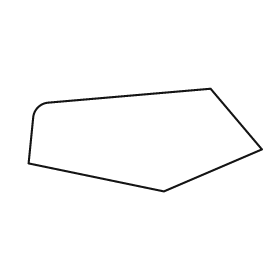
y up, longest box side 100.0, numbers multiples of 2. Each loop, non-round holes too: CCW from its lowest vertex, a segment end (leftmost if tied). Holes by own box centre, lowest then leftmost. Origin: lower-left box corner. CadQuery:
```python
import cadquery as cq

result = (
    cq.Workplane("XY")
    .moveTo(58.0, 0.0)
    .lineTo(100.0, 18.0)
    .lineTo(78.0, 44.0)
    .lineTo(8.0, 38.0)
    .threePointArc((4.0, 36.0), (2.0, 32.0))
    .lineTo(0.0, 12.0)
    .close()
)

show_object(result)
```